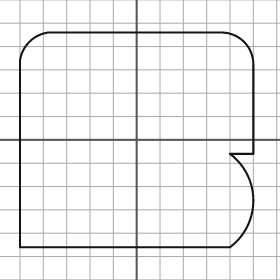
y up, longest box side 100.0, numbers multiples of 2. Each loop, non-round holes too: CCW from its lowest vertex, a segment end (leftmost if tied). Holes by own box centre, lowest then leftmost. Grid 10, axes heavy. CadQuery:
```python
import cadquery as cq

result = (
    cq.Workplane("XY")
    .moveTo(-50.0, -46.0)
    .lineTo(40.0, -46.0)
    .threePointArc((50.0, -26.0), (40.0, -6.0))
    .lineTo(50.0, -6.0)
    .lineTo(50.0, 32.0)
    .threePointArc((46.0, 42.0), (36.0, 46.0))
    .lineTo(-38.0, 46.0)
    .threePointArc((-46.0, 42.0), (-50.0, 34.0))
    .close()
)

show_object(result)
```